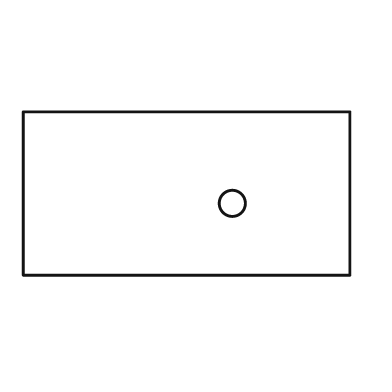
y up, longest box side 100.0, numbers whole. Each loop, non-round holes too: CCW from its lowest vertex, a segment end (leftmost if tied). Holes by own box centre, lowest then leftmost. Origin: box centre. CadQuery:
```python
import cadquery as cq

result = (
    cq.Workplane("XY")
    .moveTo(-50.0, -25.0)
    .lineTo(50.0, -25.0)
    .lineTo(50.0, 25.0)
    .lineTo(-50.0, 25.0)
    .close()
    .moveTo(14.0, -3.0)
    .circle(4.0)
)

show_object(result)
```